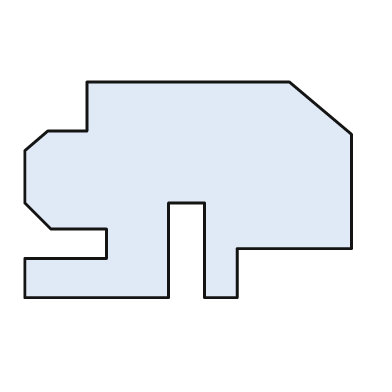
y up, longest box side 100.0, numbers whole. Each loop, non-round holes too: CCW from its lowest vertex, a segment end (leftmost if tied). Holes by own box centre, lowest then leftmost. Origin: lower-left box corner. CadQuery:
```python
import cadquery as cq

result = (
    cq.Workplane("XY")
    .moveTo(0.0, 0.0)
    .lineTo(44.0, 0.0)
    .lineTo(44.0, 29.0)
    .lineTo(55.0, 29.0)
    .lineTo(55.0, 0.0)
    .lineTo(65.0, 0.0)
    .lineTo(65.0, 15.0)
    .lineTo(100.0, 15.0)
    .lineTo(100.0, 50.0)
    .lineTo(81.0, 66.0)
    .lineTo(19.0, 66.0)
    .lineTo(19.0, 51.0)
    .lineTo(7.0, 51.0)
    .lineTo(0.0, 45.0)
    .lineTo(0.0, 29.0)
    .lineTo(8.0, 21.0)
    .lineTo(25.0, 21.0)
    .lineTo(25.0, 12.0)
    .lineTo(0.0, 12.0)
    .close()
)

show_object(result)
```